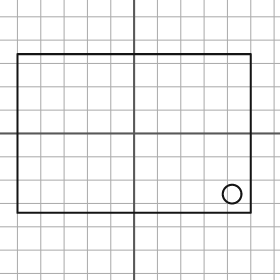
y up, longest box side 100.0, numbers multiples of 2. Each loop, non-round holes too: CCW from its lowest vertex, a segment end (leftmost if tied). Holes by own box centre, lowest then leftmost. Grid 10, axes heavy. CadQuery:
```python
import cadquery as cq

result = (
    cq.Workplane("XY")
    .moveTo(-50.0, -34.0)
    .lineTo(50.0, -34.0)
    .lineTo(50.0, 34.0)
    .lineTo(-50.0, 34.0)
    .close()
    .moveTo(42.0, -26.0)
    .circle(4.0)
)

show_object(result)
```